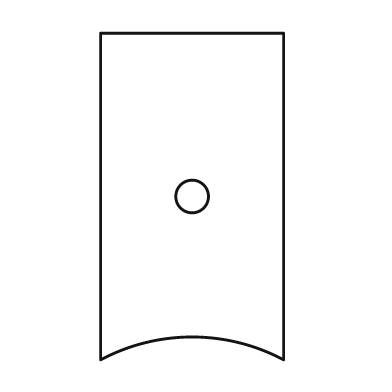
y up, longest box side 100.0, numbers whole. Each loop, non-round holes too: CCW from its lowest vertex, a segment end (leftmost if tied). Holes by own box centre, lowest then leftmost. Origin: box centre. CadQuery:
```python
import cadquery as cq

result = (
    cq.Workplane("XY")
    .moveTo(-28.0, -50.0)
    .threePointArc((0.0, -43.0), (28.0, -50.0))
    .lineTo(28.0, 50.0)
    .lineTo(-28.0, 50.0)
    .close()
    .moveTo(0.0, 0.0)
    .circle(5.0)
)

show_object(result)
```